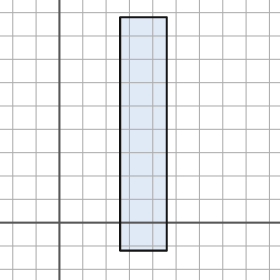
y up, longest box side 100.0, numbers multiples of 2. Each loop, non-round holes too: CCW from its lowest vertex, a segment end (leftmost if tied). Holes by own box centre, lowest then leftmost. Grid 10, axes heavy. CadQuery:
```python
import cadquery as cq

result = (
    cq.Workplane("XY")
    .moveTo(26.0, -12.0)
    .lineTo(46.0, -12.0)
    .lineTo(46.0, 88.0)
    .lineTo(26.0, 88.0)
    .close()
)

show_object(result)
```